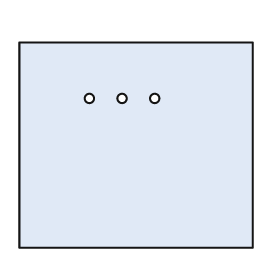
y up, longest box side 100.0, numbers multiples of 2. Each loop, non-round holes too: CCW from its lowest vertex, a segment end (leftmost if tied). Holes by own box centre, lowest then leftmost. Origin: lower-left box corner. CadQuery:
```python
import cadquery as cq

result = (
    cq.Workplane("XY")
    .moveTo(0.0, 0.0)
    .lineTo(100.0, 0.0)
    .lineTo(100.0, 88.0)
    .lineTo(0.0, 88.0)
    .close()
    .moveTo(30.0, 64.0)
    .circle(2.0)
    .moveTo(44.0, 64.0)
    .circle(2.0)
    .moveTo(58.0, 64.0)
    .circle(2.0)
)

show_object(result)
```